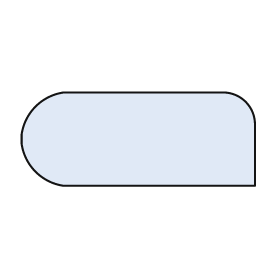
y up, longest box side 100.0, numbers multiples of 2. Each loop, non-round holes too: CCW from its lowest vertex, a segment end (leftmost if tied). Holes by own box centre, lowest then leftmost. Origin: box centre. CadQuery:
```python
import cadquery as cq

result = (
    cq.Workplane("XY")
    .moveTo(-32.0, -20.0)
    .lineTo(50.0, -20.0)
    .lineTo(50.0, 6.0)
    .threePointArc((46.0, 16.0), (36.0, 20.0))
    .lineTo(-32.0, 20.0)
    .threePointArc((-44.0, 14.0), (-50.0, 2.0))
    .lineTo(-50.0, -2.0)
    .threePointArc((-44.0, -14.0), (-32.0, -20.0))
    .close()
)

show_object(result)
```